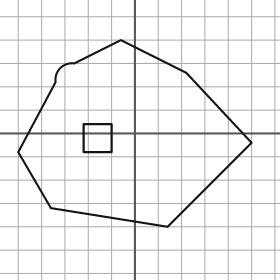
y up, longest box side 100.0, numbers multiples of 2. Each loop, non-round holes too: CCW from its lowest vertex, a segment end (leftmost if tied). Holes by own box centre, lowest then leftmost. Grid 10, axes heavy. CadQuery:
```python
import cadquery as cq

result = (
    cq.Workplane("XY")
    .moveTo(14.0, -40.0)
    .lineTo(50.0, -4.0)
    .lineTo(22.0, 26.0)
    .lineTo(-6.0, 40.0)
    .lineTo(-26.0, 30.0)
    .threePointArc((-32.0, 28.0), (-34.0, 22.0))
    .lineTo(-50.0, -8.0)
    .lineTo(-36.0, -32.0)
    .close()
    .moveTo(-22.0, -8.0)
    .lineTo(-10.0, -8.0)
    .lineTo(-10.0, 4.0)
    .lineTo(-22.0, 4.0)
    .close()
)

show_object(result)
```